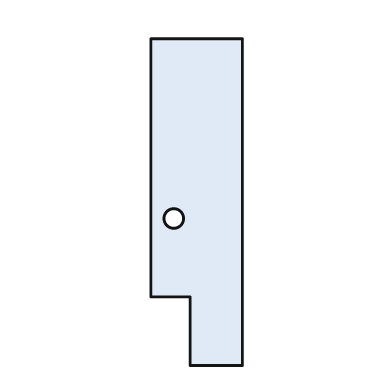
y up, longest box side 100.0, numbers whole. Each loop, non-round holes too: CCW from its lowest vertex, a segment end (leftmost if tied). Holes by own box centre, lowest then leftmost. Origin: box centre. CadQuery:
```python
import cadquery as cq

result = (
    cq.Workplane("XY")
    .moveTo(-2.0, -50.0)
    .lineTo(14.0, -50.0)
    .lineTo(14.0, 50.0)
    .lineTo(-14.0, 50.0)
    .lineTo(-14.0, -29.0)
    .lineTo(-2.0, -29.0)
    .close()
    .moveTo(-7.0, -5.0)
    .circle(3.0)
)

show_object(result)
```